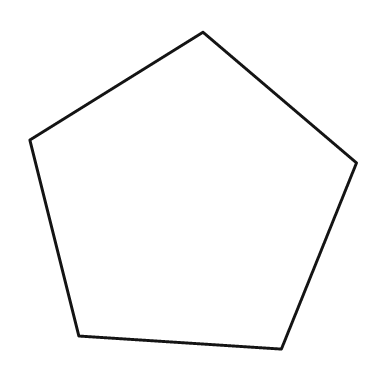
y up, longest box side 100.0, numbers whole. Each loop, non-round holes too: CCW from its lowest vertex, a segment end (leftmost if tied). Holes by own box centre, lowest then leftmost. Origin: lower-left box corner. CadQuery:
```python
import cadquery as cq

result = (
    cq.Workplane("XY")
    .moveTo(77.0, 0.0)
    .lineTo(100.0, 57.0)
    .lineTo(53.0, 97.0)
    .lineTo(0.0, 64.0)
    .lineTo(15.0, 4.0)
    .close()
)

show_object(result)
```